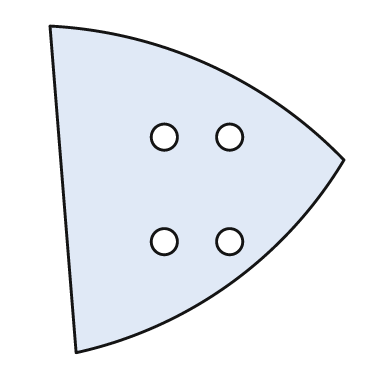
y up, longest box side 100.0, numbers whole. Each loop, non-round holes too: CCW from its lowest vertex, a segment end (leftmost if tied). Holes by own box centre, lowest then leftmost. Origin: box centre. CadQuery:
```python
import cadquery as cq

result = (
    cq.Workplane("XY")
    .moveTo(-37.0, -50.0)
    .threePointArc((10.0, -29.0), (45.0, 9.0))
    .threePointArc((4.0, 38.0), (-45.0, 50.0))
    .close()
    .moveTo(-10.0, -16.0)
    .circle(4.0)
    .moveTo(10.0, -16.0)
    .circle(4.0)
    .moveTo(-10.0, 16.0)
    .circle(4.0)
    .moveTo(10.0, 16.0)
    .circle(4.0)
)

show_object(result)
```